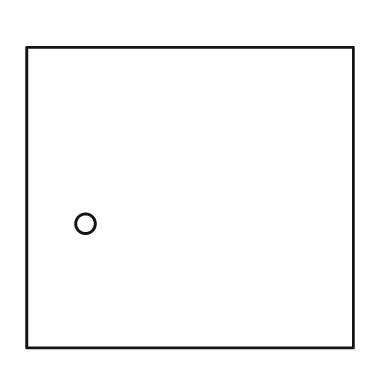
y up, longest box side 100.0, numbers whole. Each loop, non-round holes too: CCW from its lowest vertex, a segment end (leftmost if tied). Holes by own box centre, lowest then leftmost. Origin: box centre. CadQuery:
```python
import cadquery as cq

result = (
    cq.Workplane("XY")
    .moveTo(-50.0, -46.0)
    .lineTo(50.0, -46.0)
    .lineTo(50.0, 46.0)
    .lineTo(-50.0, 46.0)
    .close()
    .moveTo(-32.0, -8.0)
    .circle(3.0)
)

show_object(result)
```